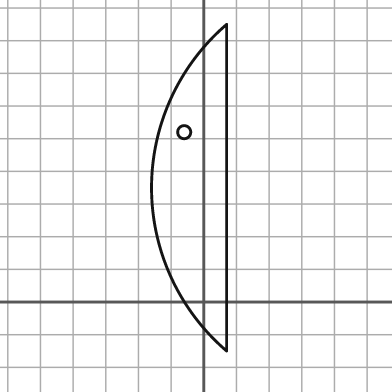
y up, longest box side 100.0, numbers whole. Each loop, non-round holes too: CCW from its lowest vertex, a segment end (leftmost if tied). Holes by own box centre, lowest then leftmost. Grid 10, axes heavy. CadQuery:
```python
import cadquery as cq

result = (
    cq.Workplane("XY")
    .moveTo(7.0, -15.0)
    .lineTo(7.0, 85.0)
    .threePointArc((-16.0, 35.0), (7.0, -15.0))
    .close()
    .moveTo(-6.0, 52.0)
    .circle(2.0)
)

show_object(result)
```